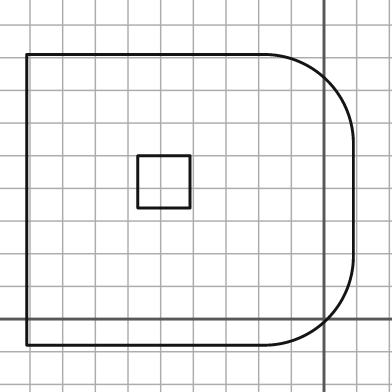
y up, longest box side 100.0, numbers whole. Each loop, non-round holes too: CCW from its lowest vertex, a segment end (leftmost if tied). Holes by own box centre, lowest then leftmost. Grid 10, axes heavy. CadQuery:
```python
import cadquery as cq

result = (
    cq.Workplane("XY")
    .moveTo(-91.0, -8.0)
    .lineTo(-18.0, -8.0)
    .threePointArc((1.0, 0.0), (9.0, 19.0))
    .lineTo(9.0, 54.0)
    .threePointArc((1.0, 73.0), (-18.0, 81.0))
    .lineTo(-91.0, 81.0)
    .close()
    .moveTo(-57.0, 34.0)
    .lineTo(-41.0, 34.0)
    .lineTo(-41.0, 50.0)
    .lineTo(-57.0, 50.0)
    .close()
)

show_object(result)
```